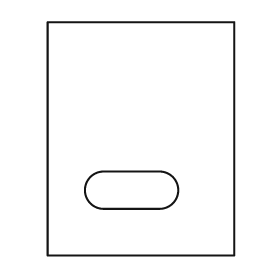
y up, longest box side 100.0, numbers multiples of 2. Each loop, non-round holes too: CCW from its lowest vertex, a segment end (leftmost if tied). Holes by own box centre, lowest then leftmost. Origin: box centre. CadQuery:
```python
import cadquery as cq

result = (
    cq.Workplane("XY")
    .moveTo(-40.0, -50.0)
    .lineTo(40.0, -50.0)
    .lineTo(40.0, 50.0)
    .lineTo(-40.0, 50.0)
    .close()
    .moveTo(-16.0, -30.0)
    .lineTo(8.0, -30.0)
    .threePointArc((16.0, -22.0), (8.0, -14.0))
    .lineTo(-16.0, -14.0)
    .threePointArc((-24.0, -22.0), (-16.0, -30.0))
    .close()
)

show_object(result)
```